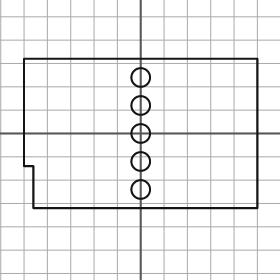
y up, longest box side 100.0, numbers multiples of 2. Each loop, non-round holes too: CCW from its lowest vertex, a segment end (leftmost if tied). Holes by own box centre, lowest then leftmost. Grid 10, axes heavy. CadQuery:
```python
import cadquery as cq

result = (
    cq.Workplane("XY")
    .moveTo(-46.0, -32.0)
    .lineTo(50.0, -32.0)
    .lineTo(50.0, 32.0)
    .lineTo(-50.0, 32.0)
    .lineTo(-50.0, -14.0)
    .lineTo(-46.0, -14.0)
    .close()
    .moveTo(0.0, -24.0)
    .circle(4.0)
    .moveTo(0.0, -12.0)
    .circle(4.0)
    .moveTo(0.0, 0.0)
    .circle(4.0)
    .moveTo(0.0, 12.0)
    .circle(4.0)
    .moveTo(0.0, 24.0)
    .circle(4.0)
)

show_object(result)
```